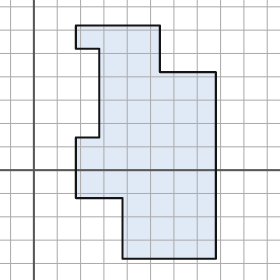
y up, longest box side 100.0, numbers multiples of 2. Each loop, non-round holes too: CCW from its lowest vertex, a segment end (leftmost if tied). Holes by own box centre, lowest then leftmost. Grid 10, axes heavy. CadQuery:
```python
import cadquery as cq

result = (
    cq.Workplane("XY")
    .moveTo(38.0, -38.0)
    .lineTo(78.0, -38.0)
    .lineTo(78.0, 42.0)
    .lineTo(54.0, 42.0)
    .lineTo(54.0, 62.0)
    .lineTo(18.0, 62.0)
    .lineTo(18.0, 52.0)
    .lineTo(28.0, 52.0)
    .lineTo(28.0, 14.0)
    .lineTo(18.0, 14.0)
    .lineTo(18.0, -12.0)
    .lineTo(38.0, -12.0)
    .close()
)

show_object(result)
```